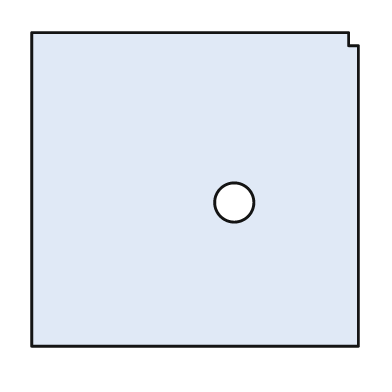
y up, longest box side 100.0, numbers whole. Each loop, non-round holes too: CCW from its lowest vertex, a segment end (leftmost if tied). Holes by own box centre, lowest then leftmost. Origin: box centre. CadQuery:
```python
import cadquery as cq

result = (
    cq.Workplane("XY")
    .moveTo(-50.0, -48.0)
    .lineTo(50.0, -48.0)
    .lineTo(50.0, 44.0)
    .lineTo(47.0, 44.0)
    .lineTo(47.0, 48.0)
    .lineTo(-50.0, 48.0)
    .close()
    .moveTo(12.0, -4.0)
    .circle(6.0)
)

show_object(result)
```